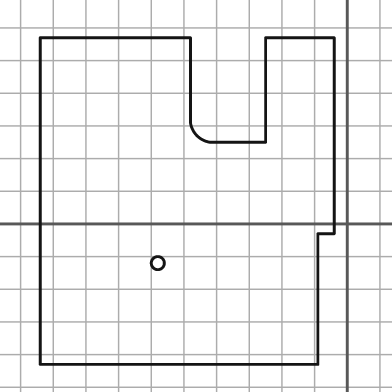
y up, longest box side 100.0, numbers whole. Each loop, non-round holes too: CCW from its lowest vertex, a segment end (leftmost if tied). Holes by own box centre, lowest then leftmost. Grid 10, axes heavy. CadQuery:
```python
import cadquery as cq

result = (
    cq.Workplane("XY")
    .moveTo(-94.0, -43.0)
    .lineTo(-9.0, -43.0)
    .lineTo(-9.0, -3.0)
    .lineTo(-4.0, -3.0)
    .lineTo(-4.0, 57.0)
    .lineTo(-25.0, 57.0)
    .lineTo(-25.0, 25.0)
    .lineTo(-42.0, 25.0)
    .threePointArc((-46.0, 27.0), (-48.0, 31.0))
    .lineTo(-48.0, 57.0)
    .lineTo(-94.0, 57.0)
    .close()
    .moveTo(-58.0, -12.0)
    .circle(2.0)
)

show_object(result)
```